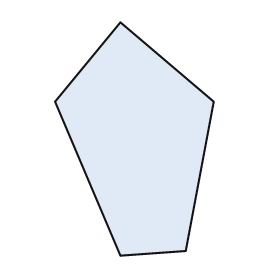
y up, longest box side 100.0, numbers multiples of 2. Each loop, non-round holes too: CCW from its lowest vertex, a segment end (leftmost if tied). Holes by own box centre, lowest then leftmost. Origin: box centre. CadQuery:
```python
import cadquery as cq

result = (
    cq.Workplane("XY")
    .moveTo(-6.0, -50.0)
    .lineTo(22.0, -48.0)
    .lineTo(34.0, 16.0)
    .lineTo(-6.0, 50.0)
    .lineTo(-34.0, 16.0)
    .close()
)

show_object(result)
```